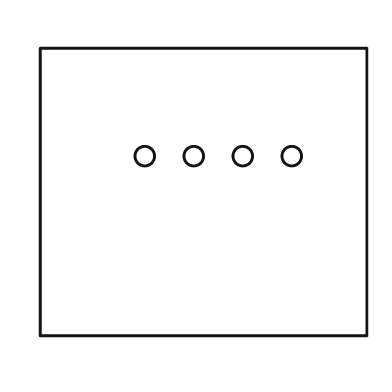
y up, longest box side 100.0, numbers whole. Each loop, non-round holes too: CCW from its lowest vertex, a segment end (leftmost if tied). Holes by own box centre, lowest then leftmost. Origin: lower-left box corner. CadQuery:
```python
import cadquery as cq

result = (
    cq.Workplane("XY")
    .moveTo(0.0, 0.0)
    .lineTo(100.0, 0.0)
    .lineTo(100.0, 88.0)
    .lineTo(0.0, 88.0)
    .close()
    .moveTo(32.0, 55.0)
    .circle(3.0)
    .moveTo(47.0, 55.0)
    .circle(3.0)
    .moveTo(62.0, 55.0)
    .circle(3.0)
    .moveTo(77.0, 55.0)
    .circle(3.0)
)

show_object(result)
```